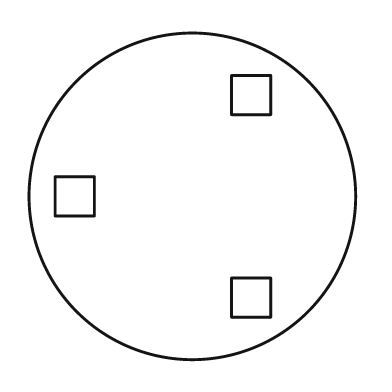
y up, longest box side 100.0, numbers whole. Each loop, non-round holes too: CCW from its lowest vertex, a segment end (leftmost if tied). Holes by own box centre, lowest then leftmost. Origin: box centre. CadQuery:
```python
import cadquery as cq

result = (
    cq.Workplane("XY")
    .moveTo(0.0, 0.0)
    .circle(50.0)
    .moveTo(12.0, -37.0)
    .lineTo(24.0, -37.0)
    .lineTo(24.0, -25.0)
    .lineTo(12.0, -25.0)
    .close()
    .moveTo(-42.0, -6.0)
    .lineTo(-30.0, -6.0)
    .lineTo(-30.0, 6.0)
    .lineTo(-42.0, 6.0)
    .close()
    .moveTo(12.0, 25.0)
    .lineTo(24.0, 25.0)
    .lineTo(24.0, 37.0)
    .lineTo(12.0, 37.0)
    .close()
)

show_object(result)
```